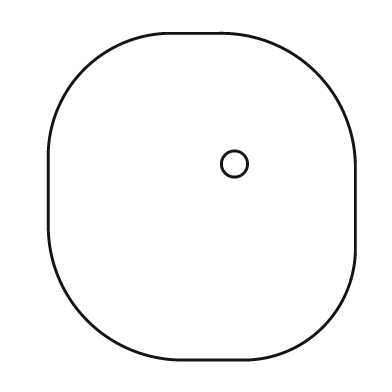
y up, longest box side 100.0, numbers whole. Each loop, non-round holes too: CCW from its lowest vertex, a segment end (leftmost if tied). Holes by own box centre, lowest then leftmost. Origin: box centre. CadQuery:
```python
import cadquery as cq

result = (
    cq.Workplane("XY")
    .moveTo(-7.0, -50.0)
    .lineTo(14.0, -50.0)
    .threePointArc((37.0, -40.0), (47.0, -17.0))
    .lineTo(47.0, 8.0)
    .threePointArc((35.0, 38.0), (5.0, 50.0))
    .lineTo(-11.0, 50.0)
    .threePointArc((-36.0, 39.0), (-47.0, 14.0))
    .lineTo(-47.0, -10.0)
    .threePointArc((-35.0, -38.0), (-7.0, -50.0))
    .close()
    .moveTo(10.0, 10.0)
    .circle(4.0)
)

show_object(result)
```